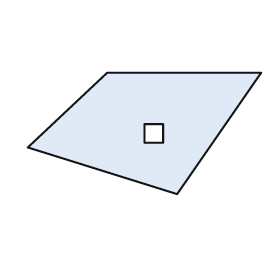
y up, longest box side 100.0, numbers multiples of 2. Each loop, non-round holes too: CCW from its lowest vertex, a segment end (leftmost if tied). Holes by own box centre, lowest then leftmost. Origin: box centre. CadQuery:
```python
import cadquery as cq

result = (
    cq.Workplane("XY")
    .moveTo(14.0, -26.0)
    .lineTo(50.0, 26.0)
    .lineTo(-16.0, 26.0)
    .lineTo(-50.0, -6.0)
    .close()
    .moveTo(0.0, -4.0)
    .lineTo(8.0, -4.0)
    .lineTo(8.0, 4.0)
    .lineTo(0.0, 4.0)
    .close()
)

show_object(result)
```